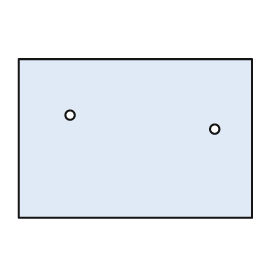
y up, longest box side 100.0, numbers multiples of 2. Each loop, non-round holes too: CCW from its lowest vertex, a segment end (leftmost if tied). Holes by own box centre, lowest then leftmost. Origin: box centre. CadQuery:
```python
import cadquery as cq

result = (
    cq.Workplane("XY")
    .moveTo(-50.0, -34.0)
    .lineTo(50.0, -34.0)
    .lineTo(50.0, 34.0)
    .lineTo(-50.0, 34.0)
    .close()
    .moveTo(34.0, 4.0)
    .circle(2.0)
    .moveTo(-28.0, 10.0)
    .circle(2.0)
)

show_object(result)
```